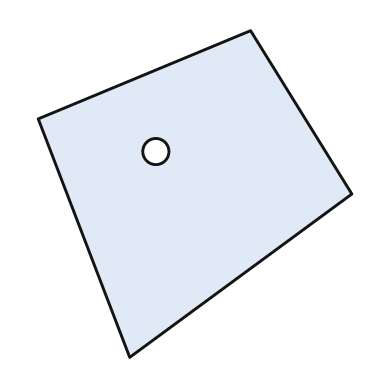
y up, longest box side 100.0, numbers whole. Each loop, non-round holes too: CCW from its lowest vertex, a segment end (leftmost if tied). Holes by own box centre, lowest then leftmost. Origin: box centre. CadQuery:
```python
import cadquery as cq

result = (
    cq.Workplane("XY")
    .moveTo(-20.0, -50.0)
    .lineTo(48.0, 0.0)
    .lineTo(17.0, 50.0)
    .lineTo(-48.0, 23.0)
    .close()
    .moveTo(-12.0, 13.0)
    .circle(4.0)
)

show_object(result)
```